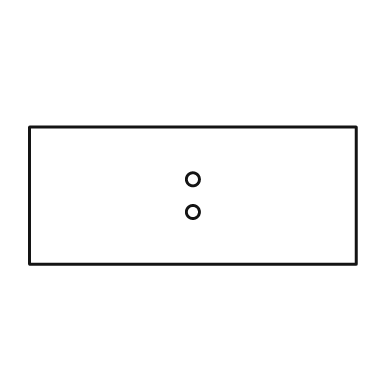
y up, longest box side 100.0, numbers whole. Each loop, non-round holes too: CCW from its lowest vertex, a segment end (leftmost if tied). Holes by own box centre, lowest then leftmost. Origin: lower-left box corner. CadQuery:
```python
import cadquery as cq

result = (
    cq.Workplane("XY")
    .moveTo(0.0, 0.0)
    .lineTo(100.0, 0.0)
    .lineTo(100.0, 42.0)
    .lineTo(0.0, 42.0)
    .close()
    .moveTo(50.0, 16.0)
    .circle(2.0)
    .moveTo(50.0, 26.0)
    .circle(2.0)
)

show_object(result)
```